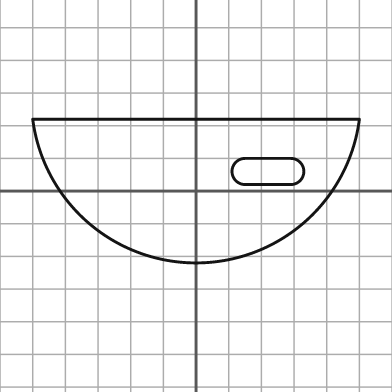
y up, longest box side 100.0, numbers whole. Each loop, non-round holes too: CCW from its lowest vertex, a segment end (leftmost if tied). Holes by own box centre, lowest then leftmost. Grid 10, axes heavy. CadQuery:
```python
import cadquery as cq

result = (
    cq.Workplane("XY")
    .moveTo(-50.0, 22.0)
    .threePointArc((0.0, -22.0), (50.0, 22.0))
    .close()
    .moveTo(15.0, 2.0)
    .lineTo(29.0, 2.0)
    .threePointArc((33.0, 6.0), (29.0, 10.0))
    .lineTo(15.0, 10.0)
    .threePointArc((11.0, 6.0), (15.0, 2.0))
    .close()
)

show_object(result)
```